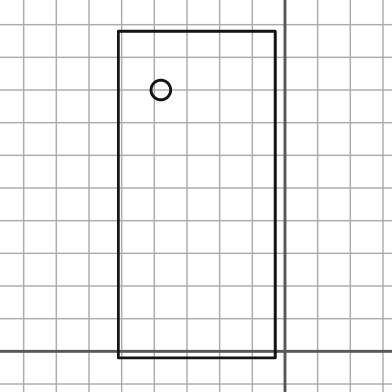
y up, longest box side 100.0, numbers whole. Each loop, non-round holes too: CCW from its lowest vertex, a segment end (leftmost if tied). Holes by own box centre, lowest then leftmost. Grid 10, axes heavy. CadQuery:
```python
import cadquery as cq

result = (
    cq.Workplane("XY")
    .moveTo(-51.0, -2.0)
    .lineTo(-3.0, -2.0)
    .lineTo(-3.0, 98.0)
    .lineTo(-51.0, 98.0)
    .close()
    .moveTo(-38.0, 80.0)
    .circle(3.0)
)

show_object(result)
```